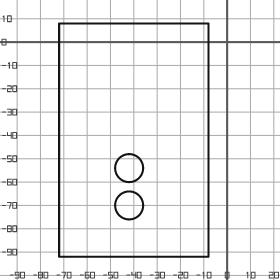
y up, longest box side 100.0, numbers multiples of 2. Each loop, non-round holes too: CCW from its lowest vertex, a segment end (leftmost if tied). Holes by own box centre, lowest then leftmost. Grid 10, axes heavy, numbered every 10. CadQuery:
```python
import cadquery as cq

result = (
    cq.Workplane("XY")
    .moveTo(-72.0, -92.0)
    .lineTo(-8.0, -92.0)
    .lineTo(-8.0, 8.0)
    .lineTo(-72.0, 8.0)
    .close()
    .moveTo(-42.0, -70.0)
    .circle(6.0)
    .moveTo(-42.0, -54.0)
    .circle(6.0)
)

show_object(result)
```